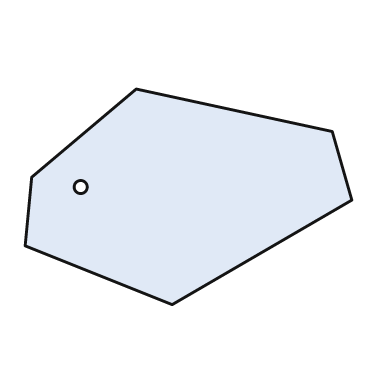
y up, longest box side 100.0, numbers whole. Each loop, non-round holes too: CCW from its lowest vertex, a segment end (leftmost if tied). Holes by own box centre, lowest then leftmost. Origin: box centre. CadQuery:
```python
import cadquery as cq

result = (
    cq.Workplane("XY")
    .moveTo(-5.0, -33.0)
    .lineTo(50.0, -1.0)
    .lineTo(44.0, 20.0)
    .lineTo(-16.0, 33.0)
    .lineTo(-48.0, 6.0)
    .lineTo(-50.0, -15.0)
    .close()
    .moveTo(-33.0, 3.0)
    .circle(2.0)
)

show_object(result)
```